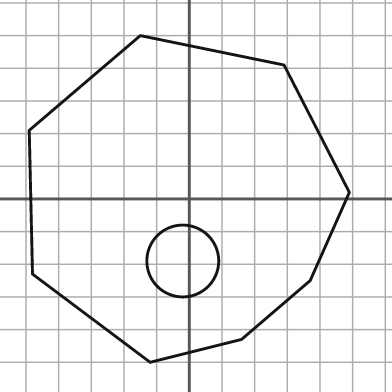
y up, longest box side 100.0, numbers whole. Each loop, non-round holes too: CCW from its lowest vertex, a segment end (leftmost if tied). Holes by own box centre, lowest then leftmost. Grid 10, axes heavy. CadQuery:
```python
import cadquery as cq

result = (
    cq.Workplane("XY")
    .moveTo(-12.0, -50.0)
    .lineTo(16.0, -43.0)
    .lineTo(37.0, -25.0)
    .lineTo(49.0, 2.0)
    .lineTo(29.0, 41.0)
    .lineTo(-15.0, 50.0)
    .lineTo(-49.0, 21.0)
    .lineTo(-48.0, -23.0)
    .close()
    .moveTo(-2.0, -19.0)
    .circle(11.0)
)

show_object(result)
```